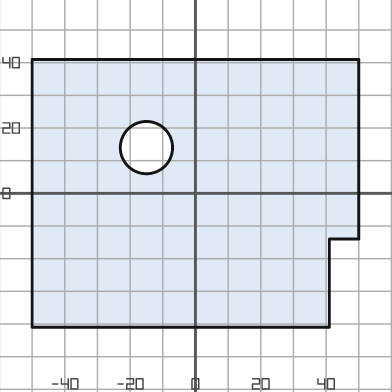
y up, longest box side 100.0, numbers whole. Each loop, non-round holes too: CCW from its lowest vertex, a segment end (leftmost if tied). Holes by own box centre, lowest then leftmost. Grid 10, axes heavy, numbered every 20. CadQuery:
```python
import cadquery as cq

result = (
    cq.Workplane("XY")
    .moveTo(-50.0, -41.0)
    .lineTo(41.0, -41.0)
    .lineTo(41.0, -14.0)
    .lineTo(50.0, -14.0)
    .lineTo(50.0, 41.0)
    .lineTo(-50.0, 41.0)
    .close()
    .moveTo(-15.0, 14.0)
    .circle(8.0)
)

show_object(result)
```